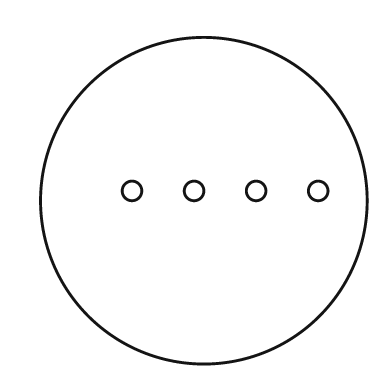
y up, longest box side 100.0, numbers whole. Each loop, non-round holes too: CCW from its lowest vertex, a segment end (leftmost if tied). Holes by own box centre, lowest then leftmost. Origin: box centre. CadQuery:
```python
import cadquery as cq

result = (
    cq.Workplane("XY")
    .moveTo(0.0, 0.0)
    .circle(50.0)
    .moveTo(-22.0, 3.0)
    .circle(3.0)
    .moveTo(-3.0, 3.0)
    .circle(3.0)
    .moveTo(16.0, 3.0)
    .circle(3.0)
    .moveTo(35.0, 3.0)
    .circle(3.0)
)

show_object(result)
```